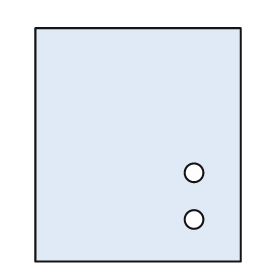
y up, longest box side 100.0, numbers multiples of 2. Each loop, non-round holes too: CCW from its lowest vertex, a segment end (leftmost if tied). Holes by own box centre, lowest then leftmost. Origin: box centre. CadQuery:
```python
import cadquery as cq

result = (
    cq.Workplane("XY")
    .moveTo(-44.0, -50.0)
    .lineTo(44.0, -50.0)
    .lineTo(44.0, 50.0)
    .lineTo(-44.0, 50.0)
    .close()
    .moveTo(24.0, -32.0)
    .circle(4.0)
    .moveTo(24.0, -12.0)
    .circle(4.0)
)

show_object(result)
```